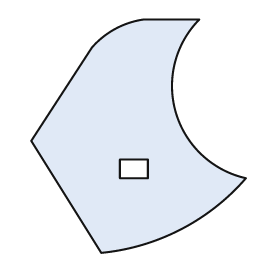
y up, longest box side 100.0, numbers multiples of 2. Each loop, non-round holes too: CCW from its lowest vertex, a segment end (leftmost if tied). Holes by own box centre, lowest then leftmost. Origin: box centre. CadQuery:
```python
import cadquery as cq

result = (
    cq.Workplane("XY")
    .moveTo(-16.0, -50.0)
    .threePointArc((18.0, -40.0), (46.0, -18.0))
    .threePointArc((16.0, 10.0), (26.0, 50.0))
    .lineTo(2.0, 50.0)
    .threePointArc((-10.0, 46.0), (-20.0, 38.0))
    .lineTo(-46.0, -2.0)
    .close()
    .moveTo(-8.0, -18.0)
    .lineTo(4.0, -18.0)
    .lineTo(4.0, -10.0)
    .lineTo(-8.0, -10.0)
    .close()
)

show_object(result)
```